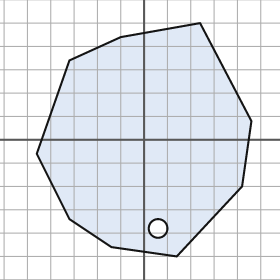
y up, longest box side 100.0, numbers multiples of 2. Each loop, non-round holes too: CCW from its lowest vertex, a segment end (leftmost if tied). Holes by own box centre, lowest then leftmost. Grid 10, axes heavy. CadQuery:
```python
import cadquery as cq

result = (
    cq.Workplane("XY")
    .moveTo(14.0, -50.0)
    .lineTo(42.0, -20.0)
    .lineTo(46.0, 8.0)
    .lineTo(24.0, 50.0)
    .lineTo(-10.0, 44.0)
    .lineTo(-32.0, 34.0)
    .lineTo(-46.0, -6.0)
    .lineTo(-32.0, -34.0)
    .lineTo(-14.0, -46.0)
    .close()
    .moveTo(6.0, -38.0)
    .circle(4.0)
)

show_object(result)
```